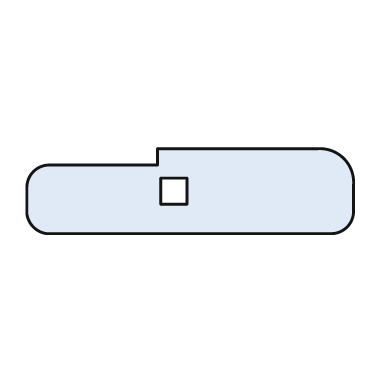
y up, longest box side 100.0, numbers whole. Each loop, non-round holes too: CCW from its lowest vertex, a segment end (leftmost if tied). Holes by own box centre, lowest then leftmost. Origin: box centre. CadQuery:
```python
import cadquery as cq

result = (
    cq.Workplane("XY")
    .moveTo(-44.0, -13.0)
    .lineTo(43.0, -13.0)
    .threePointArc((48.0, -11.0), (50.0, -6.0))
    .lineTo(50.0, 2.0)
    .threePointArc((47.0, 10.0), (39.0, 13.0))
    .lineTo(-10.0, 13.0)
    .lineTo(-10.0, 8.0)
    .lineTo(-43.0, 8.0)
    .threePointArc((-48.0, 6.0), (-50.0, 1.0))
    .lineTo(-50.0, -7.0)
    .threePointArc((-48.0, -11.0), (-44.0, -13.0))
    .close()
    .moveTo(-9.0, -4.0)
    .lineTo(-1.0, -4.0)
    .lineTo(-1.0, 4.0)
    .lineTo(-9.0, 4.0)
    .close()
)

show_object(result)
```